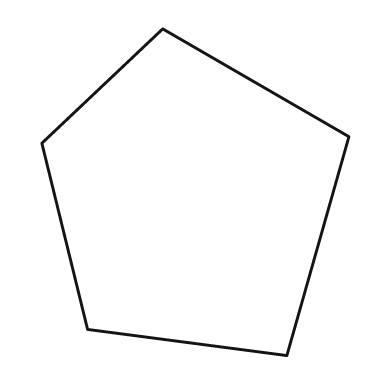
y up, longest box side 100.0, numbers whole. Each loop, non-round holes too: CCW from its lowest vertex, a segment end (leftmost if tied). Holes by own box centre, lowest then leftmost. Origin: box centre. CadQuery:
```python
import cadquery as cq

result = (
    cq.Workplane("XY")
    .moveTo(28.0, -50.0)
    .lineTo(47.0, 17.0)
    .lineTo(-10.0, 50.0)
    .lineTo(-47.0, 15.0)
    .lineTo(-33.0, -42.0)
    .close()
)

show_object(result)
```